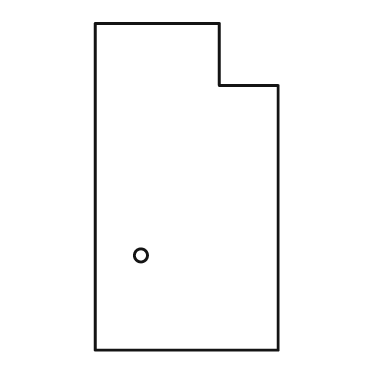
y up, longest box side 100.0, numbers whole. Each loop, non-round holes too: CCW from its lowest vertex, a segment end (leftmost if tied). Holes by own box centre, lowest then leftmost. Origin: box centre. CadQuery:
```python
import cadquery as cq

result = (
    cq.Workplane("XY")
    .moveTo(-28.0, -50.0)
    .lineTo(28.0, -50.0)
    .lineTo(28.0, 31.0)
    .lineTo(10.0, 31.0)
    .lineTo(10.0, 50.0)
    .lineTo(-28.0, 50.0)
    .close()
    .moveTo(-14.0, -21.0)
    .circle(2.0)
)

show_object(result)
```